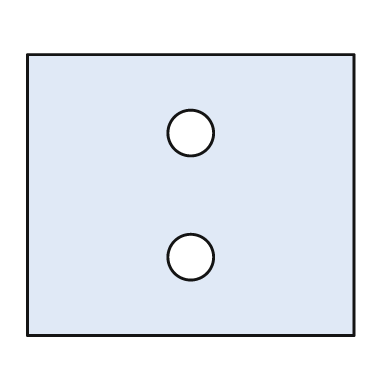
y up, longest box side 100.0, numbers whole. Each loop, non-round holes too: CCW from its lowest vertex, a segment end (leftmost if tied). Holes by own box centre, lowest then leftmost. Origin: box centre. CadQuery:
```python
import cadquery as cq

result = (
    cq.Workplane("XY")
    .moveTo(-50.0, -43.0)
    .lineTo(50.0, -43.0)
    .lineTo(50.0, 43.0)
    .lineTo(-50.0, 43.0)
    .close()
    .moveTo(0.0, -19.0)
    .circle(7.0)
    .moveTo(0.0, 19.0)
    .circle(7.0)
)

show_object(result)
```